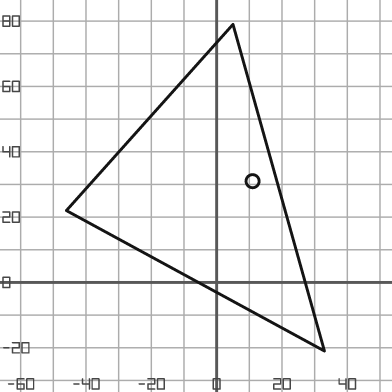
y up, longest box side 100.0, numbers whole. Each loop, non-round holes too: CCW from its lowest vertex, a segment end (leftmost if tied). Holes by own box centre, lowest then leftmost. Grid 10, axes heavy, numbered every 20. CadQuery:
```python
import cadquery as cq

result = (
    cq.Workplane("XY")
    .moveTo(33.0, -21.0)
    .lineTo(5.0, 79.0)
    .lineTo(-46.0, 22.0)
    .close()
    .moveTo(11.0, 31.0)
    .circle(2.0)
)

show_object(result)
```